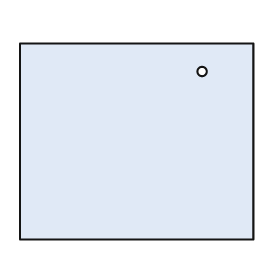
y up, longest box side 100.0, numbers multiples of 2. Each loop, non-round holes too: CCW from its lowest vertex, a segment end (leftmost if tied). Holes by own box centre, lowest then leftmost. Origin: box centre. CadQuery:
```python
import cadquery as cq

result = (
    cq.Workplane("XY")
    .moveTo(-50.0, -42.0)
    .lineTo(50.0, -42.0)
    .lineTo(50.0, 42.0)
    .lineTo(-50.0, 42.0)
    .close()
    .moveTo(28.0, 30.0)
    .circle(2.0)
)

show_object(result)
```